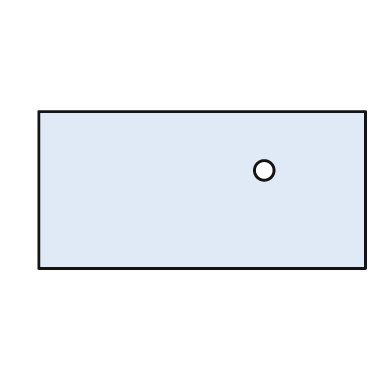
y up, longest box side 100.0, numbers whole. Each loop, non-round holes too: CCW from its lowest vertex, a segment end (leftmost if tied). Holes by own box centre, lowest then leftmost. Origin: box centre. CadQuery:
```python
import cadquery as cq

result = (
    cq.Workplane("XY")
    .moveTo(-50.0, -24.0)
    .lineTo(50.0, -24.0)
    .lineTo(50.0, 24.0)
    .lineTo(-50.0, 24.0)
    .close()
    .moveTo(19.0, 6.0)
    .circle(3.0)
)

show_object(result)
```